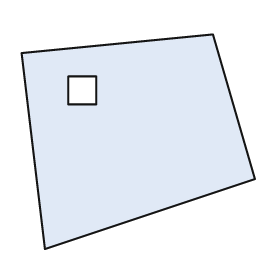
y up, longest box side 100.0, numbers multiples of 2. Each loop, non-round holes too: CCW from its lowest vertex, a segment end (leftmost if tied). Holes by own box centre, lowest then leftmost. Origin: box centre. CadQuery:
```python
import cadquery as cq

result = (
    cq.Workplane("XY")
    .moveTo(-40.0, -46.0)
    .lineTo(50.0, -16.0)
    .lineTo(32.0, 46.0)
    .lineTo(-50.0, 38.0)
    .close()
    .moveTo(-30.0, 16.0)
    .lineTo(-18.0, 16.0)
    .lineTo(-18.0, 28.0)
    .lineTo(-30.0, 28.0)
    .close()
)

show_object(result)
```